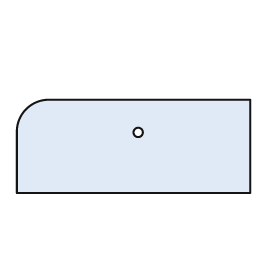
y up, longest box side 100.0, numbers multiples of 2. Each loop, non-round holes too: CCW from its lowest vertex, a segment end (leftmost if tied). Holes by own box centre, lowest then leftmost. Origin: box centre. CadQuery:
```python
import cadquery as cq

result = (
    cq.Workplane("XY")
    .moveTo(-50.0, -20.0)
    .lineTo(50.0, -20.0)
    .lineTo(50.0, 20.0)
    .lineTo(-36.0, 20.0)
    .threePointArc((-46.0, 16.0), (-50.0, 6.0))
    .close()
    .moveTo(2.0, 6.0)
    .circle(2.0)
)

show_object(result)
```